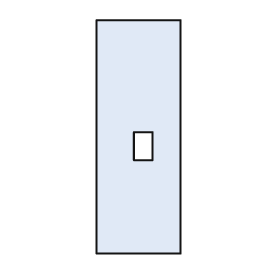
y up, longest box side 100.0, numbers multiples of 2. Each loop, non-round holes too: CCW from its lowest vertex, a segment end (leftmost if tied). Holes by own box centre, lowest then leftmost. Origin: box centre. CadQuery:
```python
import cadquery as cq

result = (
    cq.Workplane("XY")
    .moveTo(-18.0, -50.0)
    .lineTo(18.0, -50.0)
    .lineTo(18.0, 50.0)
    .lineTo(-18.0, 50.0)
    .close()
    .moveTo(-2.0, -10.0)
    .lineTo(6.0, -10.0)
    .lineTo(6.0, 2.0)
    .lineTo(-2.0, 2.0)
    .close()
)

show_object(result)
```